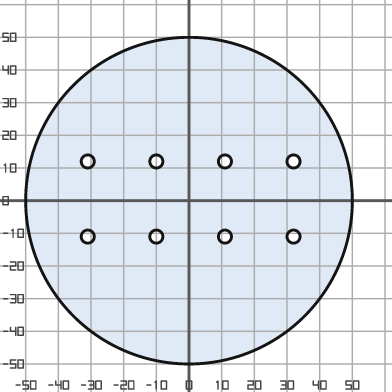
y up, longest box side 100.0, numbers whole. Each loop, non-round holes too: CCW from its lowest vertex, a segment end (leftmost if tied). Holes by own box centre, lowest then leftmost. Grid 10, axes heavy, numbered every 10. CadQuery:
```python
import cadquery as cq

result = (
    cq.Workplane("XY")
    .moveTo(0.0, 0.0)
    .circle(50.0)
    .moveTo(-31.0, -11.0)
    .circle(2.0)
    .moveTo(-10.0, -11.0)
    .circle(2.0)
    .moveTo(11.0, -11.0)
    .circle(2.0)
    .moveTo(32.0, -11.0)
    .circle(2.0)
    .moveTo(-31.0, 12.0)
    .circle(2.0)
    .moveTo(-10.0, 12.0)
    .circle(2.0)
    .moveTo(11.0, 12.0)
    .circle(2.0)
    .moveTo(32.0, 12.0)
    .circle(2.0)
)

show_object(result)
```